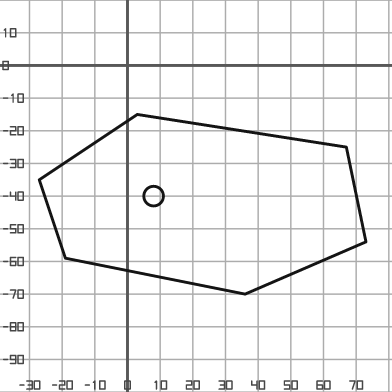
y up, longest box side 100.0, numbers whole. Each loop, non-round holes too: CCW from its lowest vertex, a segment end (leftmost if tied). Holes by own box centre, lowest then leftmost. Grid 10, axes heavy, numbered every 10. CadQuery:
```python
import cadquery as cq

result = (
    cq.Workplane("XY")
    .moveTo(36.0, -70.0)
    .lineTo(73.0, -54.0)
    .lineTo(67.0, -25.0)
    .lineTo(3.0, -15.0)
    .lineTo(-27.0, -35.0)
    .lineTo(-19.0, -59.0)
    .close()
    .moveTo(8.0, -40.0)
    .circle(3.0)
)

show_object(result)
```